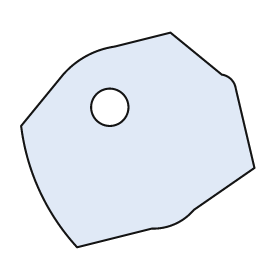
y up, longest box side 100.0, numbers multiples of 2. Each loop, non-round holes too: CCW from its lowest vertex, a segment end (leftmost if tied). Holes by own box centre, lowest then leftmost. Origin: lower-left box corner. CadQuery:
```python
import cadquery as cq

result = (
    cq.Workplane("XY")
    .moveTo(24.0, 0.0)
    .lineTo(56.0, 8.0)
    .threePointArc((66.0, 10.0), (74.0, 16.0))
    .lineTo(100.0, 34.0)
    .lineTo(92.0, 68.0)
    .threePointArc((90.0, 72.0), (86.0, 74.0))
    .lineTo(64.0, 92.0)
    .lineTo(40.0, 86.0)
    .threePointArc((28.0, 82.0), (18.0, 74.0))
    .lineTo(0.0, 52.0)
    .threePointArc((8.0, 24.0), (24.0, 0.0))
    .close()
    .moveTo(38.0, 60.0)
    .circle(8.0)
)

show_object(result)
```